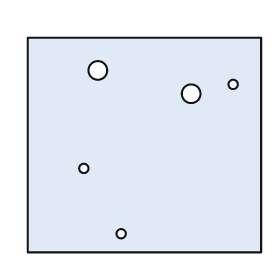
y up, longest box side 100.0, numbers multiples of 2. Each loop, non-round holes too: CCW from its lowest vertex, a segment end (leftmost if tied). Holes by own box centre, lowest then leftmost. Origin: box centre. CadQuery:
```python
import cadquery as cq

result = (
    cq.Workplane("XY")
    .moveTo(-50.0, -46.0)
    .lineTo(50.0, -46.0)
    .lineTo(50.0, 46.0)
    .lineTo(-50.0, 46.0)
    .close()
    .moveTo(-10.0, -38.0)
    .circle(2.0)
    .moveTo(-26.0, -10.0)
    .circle(2.0)
    .moveTo(20.0, 22.0)
    .circle(4.0)
    .moveTo(38.0, 26.0)
    .circle(2.0)
    .moveTo(-20.0, 32.0)
    .circle(4.0)
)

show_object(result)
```